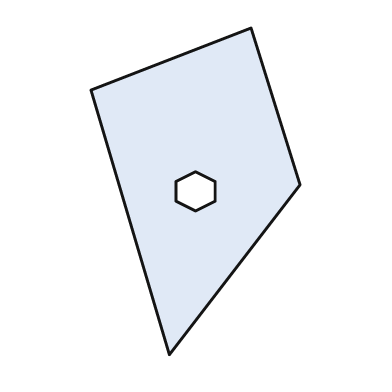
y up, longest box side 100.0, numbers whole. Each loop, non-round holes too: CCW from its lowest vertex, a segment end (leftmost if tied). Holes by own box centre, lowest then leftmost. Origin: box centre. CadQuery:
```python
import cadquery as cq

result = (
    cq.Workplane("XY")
    .moveTo(-8.0, -50.0)
    .lineTo(32.0, 2.0)
    .lineTo(17.0, 50.0)
    .lineTo(-32.0, 31.0)
    .close()
    .moveTo(0.0, -6.0)
    .lineTo(6.0, -3.0)
    .lineTo(6.0, 3.0)
    .lineTo(0.0, 6.0)
    .lineTo(-6.0, 3.0)
    .lineTo(-6.0, -3.0)
    .close()
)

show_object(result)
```